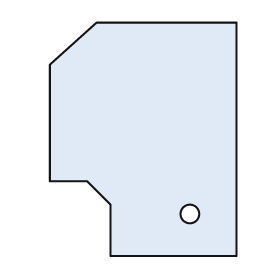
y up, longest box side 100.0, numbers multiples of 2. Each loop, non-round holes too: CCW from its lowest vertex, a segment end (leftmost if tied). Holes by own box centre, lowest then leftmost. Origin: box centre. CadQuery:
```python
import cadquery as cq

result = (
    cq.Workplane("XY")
    .moveTo(-14.0, -50.0)
    .lineTo(40.0, -50.0)
    .lineTo(40.0, 50.0)
    .lineTo(-20.0, 50.0)
    .lineTo(-40.0, 32.0)
    .lineTo(-40.0, -18.0)
    .lineTo(-24.0, -18.0)
    .lineTo(-14.0, -28.0)
    .close()
    .moveTo(20.0, -32.0)
    .circle(4.0)
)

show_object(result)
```